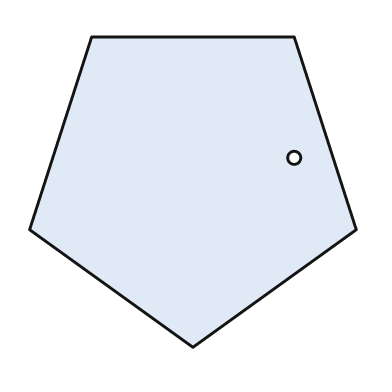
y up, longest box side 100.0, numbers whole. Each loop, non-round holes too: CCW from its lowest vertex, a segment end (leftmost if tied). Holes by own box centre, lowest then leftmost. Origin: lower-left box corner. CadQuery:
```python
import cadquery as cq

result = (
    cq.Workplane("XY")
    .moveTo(50.0, 0.0)
    .lineTo(100.0, 36.0)
    .lineTo(81.0, 95.0)
    .lineTo(19.0, 95.0)
    .lineTo(0.0, 36.0)
    .close()
    .moveTo(81.0, 58.0)
    .circle(2.0)
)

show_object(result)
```